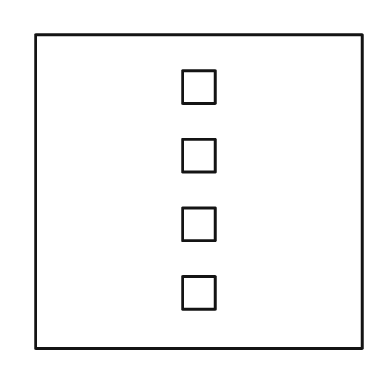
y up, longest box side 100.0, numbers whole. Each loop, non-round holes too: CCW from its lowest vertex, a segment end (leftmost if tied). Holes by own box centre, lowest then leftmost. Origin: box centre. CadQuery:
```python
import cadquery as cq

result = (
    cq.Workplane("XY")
    .moveTo(-50.0, -48.0)
    .lineTo(50.0, -48.0)
    .lineTo(50.0, 48.0)
    .lineTo(-50.0, 48.0)
    .close()
    .moveTo(-5.0, -36.0)
    .lineTo(5.0, -36.0)
    .lineTo(5.0, -26.0)
    .lineTo(-5.0, -26.0)
    .close()
    .moveTo(-5.0, -15.0)
    .lineTo(5.0, -15.0)
    .lineTo(5.0, -5.0)
    .lineTo(-5.0, -5.0)
    .close()
    .moveTo(-5.0, 6.0)
    .lineTo(5.0, 6.0)
    .lineTo(5.0, 16.0)
    .lineTo(-5.0, 16.0)
    .close()
    .moveTo(-5.0, 27.0)
    .lineTo(5.0, 27.0)
    .lineTo(5.0, 37.0)
    .lineTo(-5.0, 37.0)
    .close()
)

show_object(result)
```